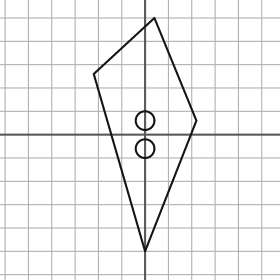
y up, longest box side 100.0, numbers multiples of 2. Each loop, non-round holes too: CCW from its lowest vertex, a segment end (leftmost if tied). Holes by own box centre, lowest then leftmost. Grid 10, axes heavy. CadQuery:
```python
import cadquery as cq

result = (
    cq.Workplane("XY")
    .moveTo(0.0, -50.0)
    .lineTo(22.0, 6.0)
    .lineTo(4.0, 50.0)
    .lineTo(-22.0, 26.0)
    .close()
    .moveTo(0.0, -6.0)
    .circle(4.0)
    .moveTo(0.0, 6.0)
    .circle(4.0)
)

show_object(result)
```